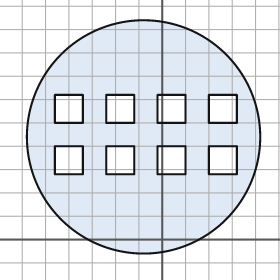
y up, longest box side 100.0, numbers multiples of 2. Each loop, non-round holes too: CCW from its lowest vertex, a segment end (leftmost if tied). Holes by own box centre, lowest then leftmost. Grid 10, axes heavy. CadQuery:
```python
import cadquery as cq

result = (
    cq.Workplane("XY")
    .moveTo(-8.0, 44.0)
    .circle(50.0)
    .moveTo(-46.0, 28.0)
    .lineTo(-34.0, 28.0)
    .lineTo(-34.0, 40.0)
    .lineTo(-46.0, 40.0)
    .close()
    .moveTo(-24.0, 28.0)
    .lineTo(-12.0, 28.0)
    .lineTo(-12.0, 40.0)
    .lineTo(-24.0, 40.0)
    .close()
    .moveTo(-2.0, 28.0)
    .lineTo(10.0, 28.0)
    .lineTo(10.0, 40.0)
    .lineTo(-2.0, 40.0)
    .close()
    .moveTo(20.0, 28.0)
    .lineTo(32.0, 28.0)
    .lineTo(32.0, 40.0)
    .lineTo(20.0, 40.0)
    .close()
    .moveTo(-46.0, 50.0)
    .lineTo(-34.0, 50.0)
    .lineTo(-34.0, 62.0)
    .lineTo(-46.0, 62.0)
    .close()
    .moveTo(-24.0, 50.0)
    .lineTo(-12.0, 50.0)
    .lineTo(-12.0, 62.0)
    .lineTo(-24.0, 62.0)
    .close()
    .moveTo(-2.0, 50.0)
    .lineTo(10.0, 50.0)
    .lineTo(10.0, 62.0)
    .lineTo(-2.0, 62.0)
    .close()
    .moveTo(20.0, 50.0)
    .lineTo(32.0, 50.0)
    .lineTo(32.0, 62.0)
    .lineTo(20.0, 62.0)
    .close()
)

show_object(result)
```